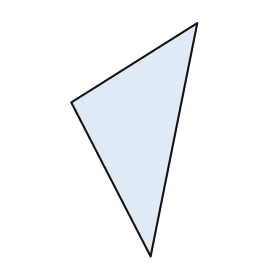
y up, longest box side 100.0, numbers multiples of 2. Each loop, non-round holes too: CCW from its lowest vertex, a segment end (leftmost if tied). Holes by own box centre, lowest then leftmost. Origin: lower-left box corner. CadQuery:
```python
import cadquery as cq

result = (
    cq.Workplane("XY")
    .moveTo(34.0, 0.0)
    .lineTo(54.0, 100.0)
    .lineTo(0.0, 66.0)
    .close()
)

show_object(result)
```